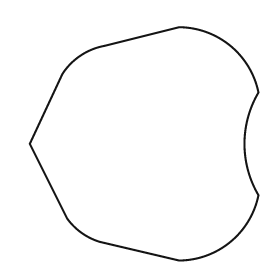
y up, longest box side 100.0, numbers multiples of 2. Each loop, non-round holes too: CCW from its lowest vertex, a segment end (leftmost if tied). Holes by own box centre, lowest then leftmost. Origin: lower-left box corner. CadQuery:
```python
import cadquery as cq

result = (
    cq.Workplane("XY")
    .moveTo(64.0, 0.0)
    .threePointArc((86.0, 8.0), (98.0, 28.0))
    .threePointArc((92.0, 50.0), (98.0, 72.0))
    .threePointArc((86.0, 92.0), (64.0, 100.0))
    .lineTo(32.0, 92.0)
    .threePointArc((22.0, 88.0), (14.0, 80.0))
    .lineTo(0.0, 50.0)
    .lineTo(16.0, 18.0)
    .threePointArc((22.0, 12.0), (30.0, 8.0))
    .close()
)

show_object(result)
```